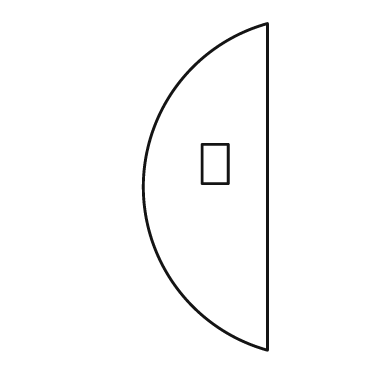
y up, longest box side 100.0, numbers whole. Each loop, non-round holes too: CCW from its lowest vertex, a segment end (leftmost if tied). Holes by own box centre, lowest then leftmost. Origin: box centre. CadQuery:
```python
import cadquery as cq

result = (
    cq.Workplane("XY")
    .moveTo(19.0, -50.0)
    .lineTo(19.0, 50.0)
    .threePointArc((-19.0, 0.0), (19.0, -50.0))
    .close()
    .moveTo(-1.0, 1.0)
    .lineTo(7.0, 1.0)
    .lineTo(7.0, 13.0)
    .lineTo(-1.0, 13.0)
    .close()
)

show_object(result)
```